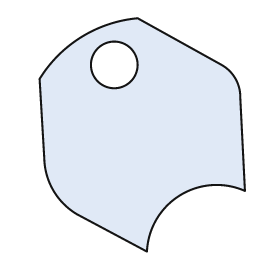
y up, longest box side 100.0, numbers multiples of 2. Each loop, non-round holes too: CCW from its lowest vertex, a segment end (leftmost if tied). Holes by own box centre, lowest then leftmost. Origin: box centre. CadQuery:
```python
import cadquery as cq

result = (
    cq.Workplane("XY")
    .moveTo(2.0, -50.0)
    .threePointArc((16.0, -26.0), (44.0, -24.0))
    .lineTo(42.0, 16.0)
    .threePointArc((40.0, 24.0), (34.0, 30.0))
    .lineTo(-2.0, 50.0)
    .threePointArc((-26.0, 42.0), (-44.0, 24.0))
    .lineTo(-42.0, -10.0)
    .threePointArc((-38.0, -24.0), (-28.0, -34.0))
    .close()
    .moveTo(-12.0, 30.0)
    .circle(10.0)
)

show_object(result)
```